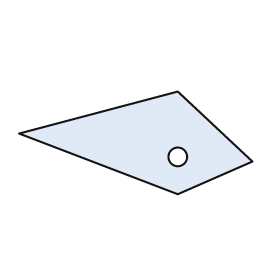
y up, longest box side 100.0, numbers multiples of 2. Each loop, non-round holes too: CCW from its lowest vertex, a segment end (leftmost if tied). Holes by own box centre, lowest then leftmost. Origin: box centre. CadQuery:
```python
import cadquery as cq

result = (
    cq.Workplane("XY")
    .moveTo(18.0, -22.0)
    .lineTo(50.0, -8.0)
    .lineTo(18.0, 22.0)
    .lineTo(-50.0, 4.0)
    .close()
    .moveTo(18.0, -6.0)
    .circle(4.0)
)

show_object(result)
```